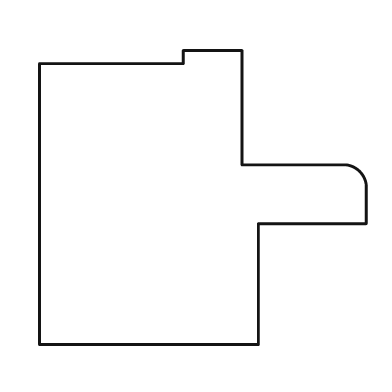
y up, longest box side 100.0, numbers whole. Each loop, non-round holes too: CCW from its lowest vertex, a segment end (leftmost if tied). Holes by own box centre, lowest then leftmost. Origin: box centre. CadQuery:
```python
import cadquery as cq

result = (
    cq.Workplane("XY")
    .moveTo(-50.0, -45.0)
    .lineTo(17.0, -45.0)
    .lineTo(17.0, -8.0)
    .lineTo(50.0, -8.0)
    .lineTo(50.0, 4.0)
    .threePointArc((48.0, 8.0), (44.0, 10.0))
    .lineTo(12.0, 10.0)
    .lineTo(12.0, 45.0)
    .lineTo(-6.0, 45.0)
    .lineTo(-6.0, 41.0)
    .lineTo(-50.0, 41.0)
    .close()
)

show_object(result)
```